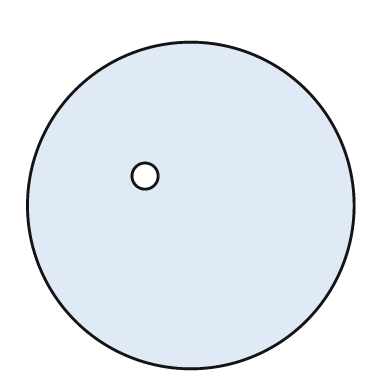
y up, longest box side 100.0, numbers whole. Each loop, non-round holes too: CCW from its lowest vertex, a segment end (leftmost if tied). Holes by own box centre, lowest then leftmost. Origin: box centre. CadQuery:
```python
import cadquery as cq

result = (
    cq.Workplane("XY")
    .moveTo(0.0, 0.0)
    .circle(50.0)
    .moveTo(-14.0, 9.0)
    .circle(4.0)
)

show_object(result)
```